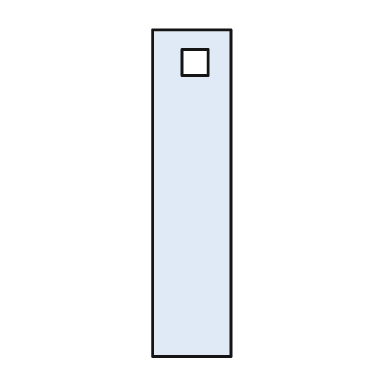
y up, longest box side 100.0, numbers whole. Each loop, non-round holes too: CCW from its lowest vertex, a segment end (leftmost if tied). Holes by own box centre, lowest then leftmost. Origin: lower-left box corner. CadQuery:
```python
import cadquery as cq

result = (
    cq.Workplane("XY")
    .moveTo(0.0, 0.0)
    .lineTo(24.0, 0.0)
    .lineTo(24.0, 100.0)
    .lineTo(0.0, 100.0)
    .close()
    .moveTo(9.0, 86.0)
    .lineTo(17.0, 86.0)
    .lineTo(17.0, 94.0)
    .lineTo(9.0, 94.0)
    .close()
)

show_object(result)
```